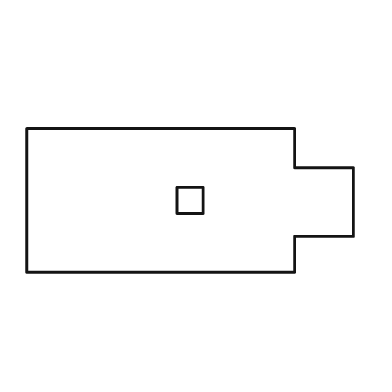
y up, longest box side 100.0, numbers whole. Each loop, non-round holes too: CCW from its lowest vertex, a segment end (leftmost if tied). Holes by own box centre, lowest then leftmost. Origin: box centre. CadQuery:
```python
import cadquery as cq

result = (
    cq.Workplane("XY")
    .moveTo(-50.0, -22.0)
    .lineTo(32.0, -22.0)
    .lineTo(32.0, -11.0)
    .lineTo(50.0, -11.0)
    .lineTo(50.0, 10.0)
    .lineTo(32.0, 10.0)
    .lineTo(32.0, 22.0)
    .lineTo(-50.0, 22.0)
    .close()
    .moveTo(-4.0, -4.0)
    .lineTo(4.0, -4.0)
    .lineTo(4.0, 4.0)
    .lineTo(-4.0, 4.0)
    .close()
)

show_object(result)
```